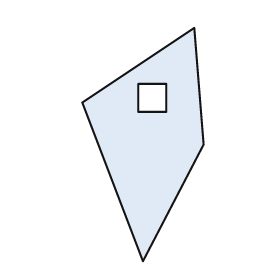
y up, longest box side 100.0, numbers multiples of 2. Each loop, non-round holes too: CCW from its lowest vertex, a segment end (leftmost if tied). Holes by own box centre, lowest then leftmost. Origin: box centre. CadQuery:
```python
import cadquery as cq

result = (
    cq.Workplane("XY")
    .moveTo(0.0, -50.0)
    .lineTo(26.0, 0.0)
    .lineTo(22.0, 50.0)
    .lineTo(-26.0, 18.0)
    .close()
    .moveTo(-2.0, 14.0)
    .lineTo(10.0, 14.0)
    .lineTo(10.0, 26.0)
    .lineTo(-2.0, 26.0)
    .close()
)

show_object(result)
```